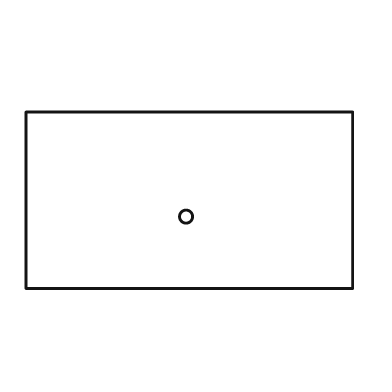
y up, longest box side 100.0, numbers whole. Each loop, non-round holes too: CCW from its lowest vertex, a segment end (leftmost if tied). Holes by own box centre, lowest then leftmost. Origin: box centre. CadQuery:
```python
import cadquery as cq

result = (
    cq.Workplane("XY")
    .moveTo(-50.0, -27.0)
    .lineTo(50.0, -27.0)
    .lineTo(50.0, 27.0)
    .lineTo(-50.0, 27.0)
    .close()
    .moveTo(-1.0, -5.0)
    .circle(2.0)
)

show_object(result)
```